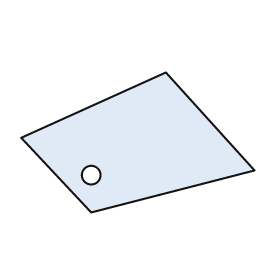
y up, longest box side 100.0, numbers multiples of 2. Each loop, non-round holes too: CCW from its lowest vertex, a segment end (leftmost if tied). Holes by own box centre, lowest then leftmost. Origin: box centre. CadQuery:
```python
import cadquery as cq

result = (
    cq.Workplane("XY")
    .moveTo(-20.0, -30.0)
    .lineTo(50.0, -12.0)
    .lineTo(12.0, 30.0)
    .lineTo(-50.0, 2.0)
    .close()
    .moveTo(-20.0, -14.0)
    .circle(4.0)
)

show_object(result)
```